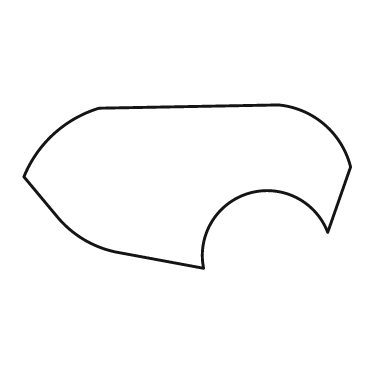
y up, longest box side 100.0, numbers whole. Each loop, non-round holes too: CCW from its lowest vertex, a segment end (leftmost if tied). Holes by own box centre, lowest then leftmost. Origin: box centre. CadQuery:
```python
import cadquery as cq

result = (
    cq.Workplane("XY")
    .moveTo(5.0, -25.0)
    .threePointArc((19.0, -2.0), (43.0, -14.0))
    .lineTo(50.0, 6.0)
    .threePointArc((42.0, 19.0), (28.0, 25.0))
    .lineTo(-27.0, 24.0)
    .threePointArc((-41.0, 16.0), (-50.0, 3.0))
    .lineTo(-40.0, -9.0)
    .threePointArc((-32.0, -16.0), (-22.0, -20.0))
    .close()
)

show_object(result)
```